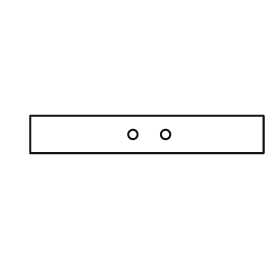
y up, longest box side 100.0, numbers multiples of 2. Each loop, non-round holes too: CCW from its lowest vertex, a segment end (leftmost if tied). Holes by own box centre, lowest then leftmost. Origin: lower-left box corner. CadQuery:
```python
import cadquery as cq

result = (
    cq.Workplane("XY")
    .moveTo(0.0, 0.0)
    .lineTo(100.0, 0.0)
    .lineTo(100.0, 16.0)
    .lineTo(0.0, 16.0)
    .close()
    .moveTo(44.0, 8.0)
    .circle(2.0)
    .moveTo(58.0, 8.0)
    .circle(2.0)
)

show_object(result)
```